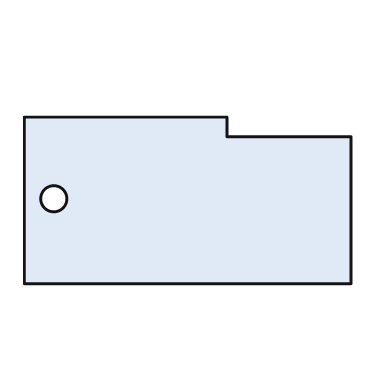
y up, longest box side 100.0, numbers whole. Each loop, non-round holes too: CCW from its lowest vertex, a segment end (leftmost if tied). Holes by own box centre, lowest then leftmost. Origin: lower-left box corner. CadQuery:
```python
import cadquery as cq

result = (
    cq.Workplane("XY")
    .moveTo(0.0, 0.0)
    .lineTo(100.0, 0.0)
    .lineTo(100.0, 45.0)
    .lineTo(62.0, 45.0)
    .lineTo(62.0, 51.0)
    .lineTo(0.0, 51.0)
    .close()
    .moveTo(9.0, 26.0)
    .circle(4.0)
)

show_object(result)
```